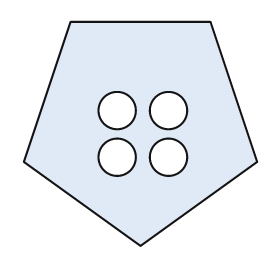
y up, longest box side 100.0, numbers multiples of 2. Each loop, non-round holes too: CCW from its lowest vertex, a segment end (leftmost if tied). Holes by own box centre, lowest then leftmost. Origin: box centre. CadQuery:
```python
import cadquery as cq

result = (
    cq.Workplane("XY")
    .moveTo(0.0, -48.0)
    .lineTo(50.0, -12.0)
    .lineTo(30.0, 48.0)
    .lineTo(-30.0, 48.0)
    .lineTo(-50.0, -12.0)
    .close()
    .moveTo(-10.0, -10.0)
    .circle(8.0)
    .moveTo(12.0, -10.0)
    .circle(8.0)
    .moveTo(-10.0, 10.0)
    .circle(8.0)
    .moveTo(12.0, 10.0)
    .circle(8.0)
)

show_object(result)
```